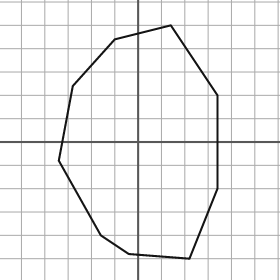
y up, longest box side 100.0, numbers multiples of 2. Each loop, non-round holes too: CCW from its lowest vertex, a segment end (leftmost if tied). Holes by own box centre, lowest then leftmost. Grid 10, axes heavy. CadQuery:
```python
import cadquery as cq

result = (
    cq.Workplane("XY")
    .moveTo(22.0, -50.0)
    .lineTo(34.0, -20.0)
    .lineTo(34.0, 20.0)
    .lineTo(14.0, 50.0)
    .lineTo(-10.0, 44.0)
    .lineTo(-28.0, 24.0)
    .lineTo(-34.0, -8.0)
    .lineTo(-16.0, -40.0)
    .lineTo(-4.0, -48.0)
    .close()
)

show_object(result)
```